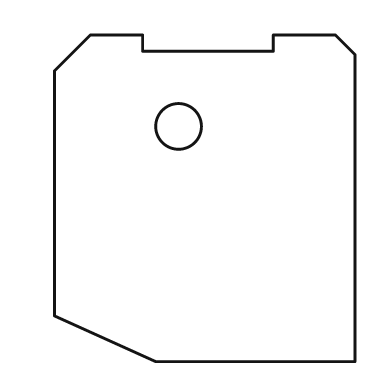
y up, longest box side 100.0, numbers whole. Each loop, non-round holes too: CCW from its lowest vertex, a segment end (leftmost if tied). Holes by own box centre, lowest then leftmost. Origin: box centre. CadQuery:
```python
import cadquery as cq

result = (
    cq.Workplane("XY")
    .moveTo(-15.0, -50.0)
    .lineTo(46.0, -50.0)
    .lineTo(46.0, 44.0)
    .lineTo(40.0, 50.0)
    .lineTo(21.0, 50.0)
    .lineTo(21.0, 45.0)
    .lineTo(-19.0, 45.0)
    .lineTo(-19.0, 50.0)
    .lineTo(-35.0, 50.0)
    .lineTo(-46.0, 39.0)
    .lineTo(-46.0, -36.0)
    .close()
    .moveTo(-8.0, 22.0)
    .circle(7.0)
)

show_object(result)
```